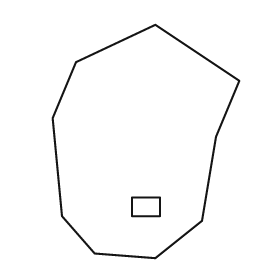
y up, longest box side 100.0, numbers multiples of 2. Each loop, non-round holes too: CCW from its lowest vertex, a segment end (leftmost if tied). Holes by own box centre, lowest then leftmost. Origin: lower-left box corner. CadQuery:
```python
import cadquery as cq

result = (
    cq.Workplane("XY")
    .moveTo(44.0, 0.0)
    .lineTo(64.0, 16.0)
    .lineTo(70.0, 52.0)
    .lineTo(80.0, 76.0)
    .lineTo(44.0, 100.0)
    .lineTo(10.0, 84.0)
    .lineTo(0.0, 60.0)
    .lineTo(4.0, 18.0)
    .lineTo(18.0, 2.0)
    .close()
    .moveTo(34.0, 18.0)
    .lineTo(46.0, 18.0)
    .lineTo(46.0, 26.0)
    .lineTo(34.0, 26.0)
    .close()
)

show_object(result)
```